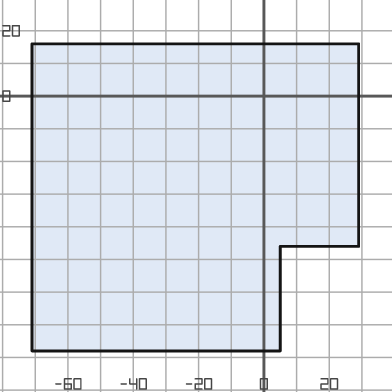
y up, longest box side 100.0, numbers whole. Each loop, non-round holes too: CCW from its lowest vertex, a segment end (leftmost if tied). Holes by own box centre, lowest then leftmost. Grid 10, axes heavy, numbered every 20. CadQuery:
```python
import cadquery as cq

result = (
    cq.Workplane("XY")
    .moveTo(-71.0, -78.0)
    .lineTo(5.0, -78.0)
    .lineTo(5.0, -46.0)
    .lineTo(29.0, -46.0)
    .lineTo(29.0, 16.0)
    .lineTo(-71.0, 16.0)
    .close()
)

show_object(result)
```